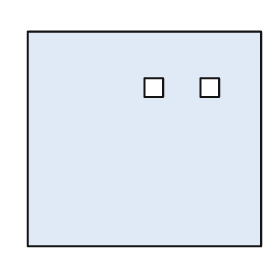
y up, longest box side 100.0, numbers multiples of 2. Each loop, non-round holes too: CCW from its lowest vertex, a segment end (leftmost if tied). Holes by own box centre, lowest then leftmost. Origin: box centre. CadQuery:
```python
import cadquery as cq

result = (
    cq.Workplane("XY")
    .moveTo(-50.0, -46.0)
    .lineTo(50.0, -46.0)
    .lineTo(50.0, 46.0)
    .lineTo(-50.0, 46.0)
    .close()
    .moveTo(0.0, 18.0)
    .lineTo(8.0, 18.0)
    .lineTo(8.0, 26.0)
    .lineTo(0.0, 26.0)
    .close()
    .moveTo(24.0, 18.0)
    .lineTo(32.0, 18.0)
    .lineTo(32.0, 26.0)
    .lineTo(24.0, 26.0)
    .close()
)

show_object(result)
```